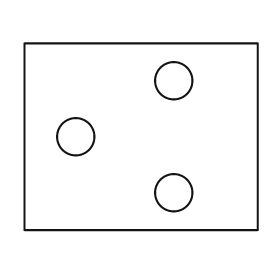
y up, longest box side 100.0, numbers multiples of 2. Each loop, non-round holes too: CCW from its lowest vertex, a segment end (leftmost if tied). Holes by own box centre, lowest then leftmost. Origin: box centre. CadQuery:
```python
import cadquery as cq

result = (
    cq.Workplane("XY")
    .moveTo(-50.0, -40.0)
    .lineTo(50.0, -40.0)
    .lineTo(50.0, 40.0)
    .lineTo(-50.0, 40.0)
    .close()
    .moveTo(14.0, -24.0)
    .circle(8.0)
    .moveTo(-28.0, 0.0)
    .circle(8.0)
    .moveTo(14.0, 24.0)
    .circle(8.0)
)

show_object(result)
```